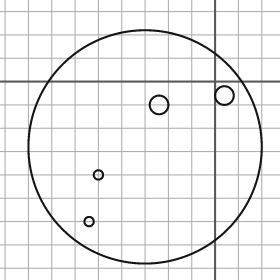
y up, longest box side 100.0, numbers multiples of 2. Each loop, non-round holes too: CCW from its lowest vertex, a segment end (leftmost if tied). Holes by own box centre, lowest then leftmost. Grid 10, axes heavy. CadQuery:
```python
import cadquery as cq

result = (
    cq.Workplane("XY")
    .moveTo(-30.0, -28.0)
    .circle(50.0)
    .moveTo(-54.0, -60.0)
    .circle(2.0)
    .moveTo(-50.0, -40.0)
    .circle(2.0)
    .moveTo(-24.0, -10.0)
    .circle(4.0)
    .moveTo(4.0, -6.0)
    .circle(4.0)
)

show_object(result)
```